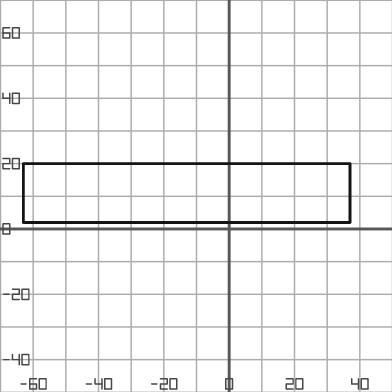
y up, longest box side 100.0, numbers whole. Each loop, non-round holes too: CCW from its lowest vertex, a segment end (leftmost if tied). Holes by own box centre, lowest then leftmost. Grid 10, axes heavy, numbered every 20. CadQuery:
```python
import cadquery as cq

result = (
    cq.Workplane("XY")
    .moveTo(-63.0, 2.0)
    .lineTo(37.0, 2.0)
    .lineTo(37.0, 20.0)
    .lineTo(-63.0, 20.0)
    .close()
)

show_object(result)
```